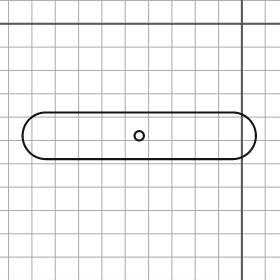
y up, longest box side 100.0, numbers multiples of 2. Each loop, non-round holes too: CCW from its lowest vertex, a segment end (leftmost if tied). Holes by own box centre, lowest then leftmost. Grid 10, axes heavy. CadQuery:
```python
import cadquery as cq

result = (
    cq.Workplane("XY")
    .moveTo(-84.0, -58.0)
    .lineTo(-4.0, -58.0)
    .threePointArc((6.0, -48.0), (-4.0, -38.0))
    .lineTo(-84.0, -38.0)
    .threePointArc((-94.0, -48.0), (-84.0, -58.0))
    .close()
    .moveTo(-44.0, -48.0)
    .circle(2.0)
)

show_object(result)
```